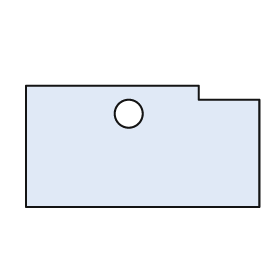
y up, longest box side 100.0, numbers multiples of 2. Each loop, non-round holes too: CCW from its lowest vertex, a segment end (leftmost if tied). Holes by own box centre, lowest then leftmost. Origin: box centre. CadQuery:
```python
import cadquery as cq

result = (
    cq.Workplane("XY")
    .moveTo(-50.0, -26.0)
    .lineTo(50.0, -26.0)
    .lineTo(50.0, 20.0)
    .lineTo(24.0, 20.0)
    .lineTo(24.0, 26.0)
    .lineTo(-50.0, 26.0)
    .close()
    .moveTo(-6.0, 14.0)
    .circle(6.0)
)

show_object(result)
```